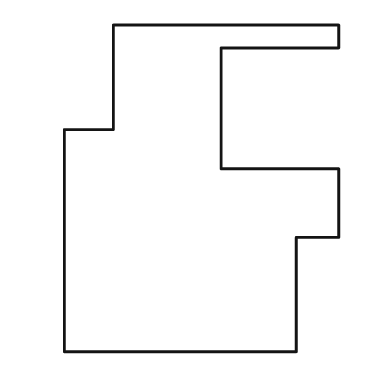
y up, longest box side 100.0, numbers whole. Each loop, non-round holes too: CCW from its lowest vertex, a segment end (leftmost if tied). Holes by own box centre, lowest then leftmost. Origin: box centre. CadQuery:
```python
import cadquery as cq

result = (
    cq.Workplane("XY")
    .moveTo(-42.0, -50.0)
    .lineTo(29.0, -50.0)
    .lineTo(29.0, -15.0)
    .lineTo(42.0, -15.0)
    .lineTo(42.0, 6.0)
    .lineTo(6.0, 6.0)
    .lineTo(6.0, 43.0)
    .lineTo(42.0, 43.0)
    .lineTo(42.0, 50.0)
    .lineTo(-27.0, 50.0)
    .lineTo(-27.0, 18.0)
    .lineTo(-42.0, 18.0)
    .close()
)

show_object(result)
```